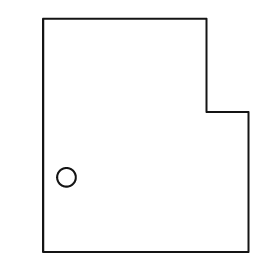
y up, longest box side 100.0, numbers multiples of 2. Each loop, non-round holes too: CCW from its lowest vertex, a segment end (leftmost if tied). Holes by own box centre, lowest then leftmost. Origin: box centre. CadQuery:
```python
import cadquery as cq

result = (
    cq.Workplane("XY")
    .moveTo(-44.0, -50.0)
    .lineTo(44.0, -50.0)
    .lineTo(44.0, 10.0)
    .lineTo(26.0, 10.0)
    .lineTo(26.0, 50.0)
    .lineTo(-44.0, 50.0)
    .close()
    .moveTo(-34.0, -18.0)
    .circle(4.0)
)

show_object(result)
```